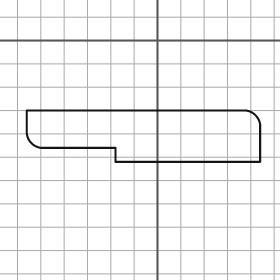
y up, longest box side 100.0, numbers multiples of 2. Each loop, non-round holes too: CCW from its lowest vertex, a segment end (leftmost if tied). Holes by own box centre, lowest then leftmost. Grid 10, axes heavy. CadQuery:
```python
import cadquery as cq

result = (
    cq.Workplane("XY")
    .moveTo(-18.0, -52.0)
    .lineTo(44.0, -52.0)
    .lineTo(44.0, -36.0)
    .threePointArc((42.0, -32.0), (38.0, -30.0))
    .lineTo(-56.0, -30.0)
    .lineTo(-56.0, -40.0)
    .threePointArc((-54.0, -44.0), (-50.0, -46.0))
    .lineTo(-18.0, -46.0)
    .close()
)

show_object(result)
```